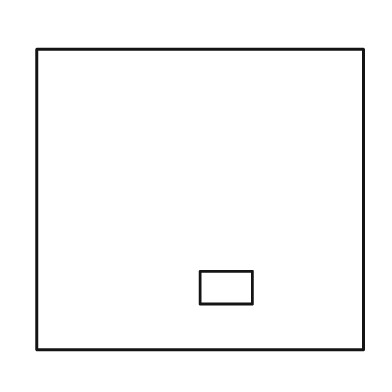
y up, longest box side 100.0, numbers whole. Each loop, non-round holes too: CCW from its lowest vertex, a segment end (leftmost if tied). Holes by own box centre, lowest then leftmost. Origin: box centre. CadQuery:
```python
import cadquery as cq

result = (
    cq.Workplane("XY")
    .moveTo(-50.0, -46.0)
    .lineTo(50.0, -46.0)
    .lineTo(50.0, 46.0)
    .lineTo(-50.0, 46.0)
    .close()
    .moveTo(0.0, -32.0)
    .lineTo(16.0, -32.0)
    .lineTo(16.0, -22.0)
    .lineTo(0.0, -22.0)
    .close()
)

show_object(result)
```